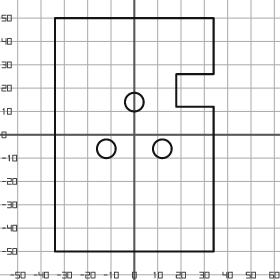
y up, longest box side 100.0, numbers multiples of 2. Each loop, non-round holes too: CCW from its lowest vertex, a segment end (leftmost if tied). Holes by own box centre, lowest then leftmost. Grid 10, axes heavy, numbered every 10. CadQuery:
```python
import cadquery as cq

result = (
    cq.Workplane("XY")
    .moveTo(-34.0, -50.0)
    .lineTo(34.0, -50.0)
    .lineTo(34.0, 12.0)
    .lineTo(18.0, 12.0)
    .lineTo(18.0, 26.0)
    .lineTo(34.0, 26.0)
    .lineTo(34.0, 50.0)
    .lineTo(-34.0, 50.0)
    .close()
    .moveTo(-12.0, -6.0)
    .circle(4.0)
    .moveTo(12.0, -6.0)
    .circle(4.0)
    .moveTo(0.0, 14.0)
    .circle(4.0)
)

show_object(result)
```